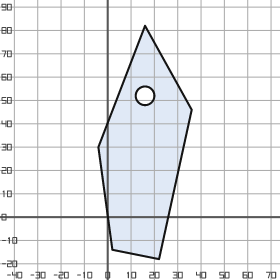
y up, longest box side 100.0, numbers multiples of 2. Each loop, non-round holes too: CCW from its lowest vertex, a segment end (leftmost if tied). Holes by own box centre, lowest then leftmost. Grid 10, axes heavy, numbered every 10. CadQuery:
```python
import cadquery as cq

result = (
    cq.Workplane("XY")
    .moveTo(22.0, -18.0)
    .lineTo(36.0, 46.0)
    .lineTo(16.0, 82.0)
    .lineTo(-4.0, 30.0)
    .lineTo(2.0, -14.0)
    .close()
    .moveTo(16.0, 52.0)
    .circle(4.0)
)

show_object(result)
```